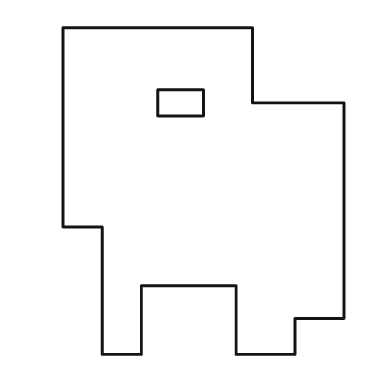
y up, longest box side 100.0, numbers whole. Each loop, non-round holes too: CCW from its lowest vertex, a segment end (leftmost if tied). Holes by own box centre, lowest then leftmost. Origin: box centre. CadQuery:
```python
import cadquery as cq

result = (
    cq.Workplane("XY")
    .moveTo(-31.0, -50.0)
    .lineTo(-19.0, -50.0)
    .lineTo(-19.0, -29.0)
    .lineTo(10.0, -29.0)
    .lineTo(10.0, -50.0)
    .lineTo(28.0, -50.0)
    .lineTo(28.0, -39.0)
    .lineTo(43.0, -39.0)
    .lineTo(43.0, 27.0)
    .lineTo(15.0, 27.0)
    .lineTo(15.0, 50.0)
    .lineTo(-43.0, 50.0)
    .lineTo(-43.0, -11.0)
    .lineTo(-31.0, -11.0)
    .close()
    .moveTo(-14.0, 23.0)
    .lineTo(0.0, 23.0)
    .lineTo(0.0, 31.0)
    .lineTo(-14.0, 31.0)
    .close()
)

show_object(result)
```